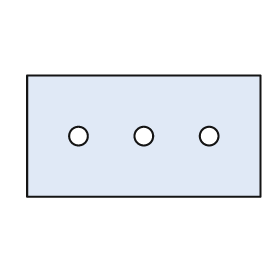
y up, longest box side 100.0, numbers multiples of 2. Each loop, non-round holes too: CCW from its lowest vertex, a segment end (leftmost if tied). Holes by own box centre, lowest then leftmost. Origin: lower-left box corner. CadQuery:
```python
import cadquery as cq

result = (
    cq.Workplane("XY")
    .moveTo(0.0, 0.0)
    .lineTo(100.0, 0.0)
    .lineTo(100.0, 52.0)
    .lineTo(0.0, 52.0)
    .close()
    .moveTo(22.0, 26.0)
    .circle(4.0)
    .moveTo(50.0, 26.0)
    .circle(4.0)
    .moveTo(78.0, 26.0)
    .circle(4.0)
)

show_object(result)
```